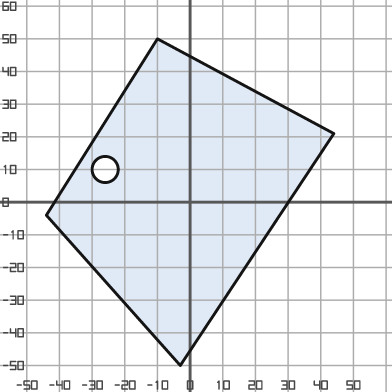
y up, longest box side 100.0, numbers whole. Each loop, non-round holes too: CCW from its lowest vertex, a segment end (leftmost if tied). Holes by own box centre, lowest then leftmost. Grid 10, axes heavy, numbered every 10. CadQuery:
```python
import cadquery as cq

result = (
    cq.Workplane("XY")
    .moveTo(-3.0, -50.0)
    .lineTo(44.0, 21.0)
    .lineTo(-10.0, 50.0)
    .lineTo(-44.0, -4.0)
    .close()
    .moveTo(-26.0, 10.0)
    .circle(4.0)
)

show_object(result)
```